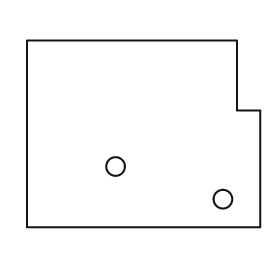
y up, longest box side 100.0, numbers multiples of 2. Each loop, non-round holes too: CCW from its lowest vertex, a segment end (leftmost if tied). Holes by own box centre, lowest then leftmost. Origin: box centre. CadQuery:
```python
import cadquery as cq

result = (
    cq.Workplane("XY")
    .moveTo(-50.0, -40.0)
    .lineTo(50.0, -40.0)
    .lineTo(50.0, 10.0)
    .lineTo(40.0, 10.0)
    .lineTo(40.0, 40.0)
    .lineTo(-50.0, 40.0)
    .close()
    .moveTo(34.0, -28.0)
    .circle(4.0)
    .moveTo(-12.0, -14.0)
    .circle(4.0)
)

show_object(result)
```